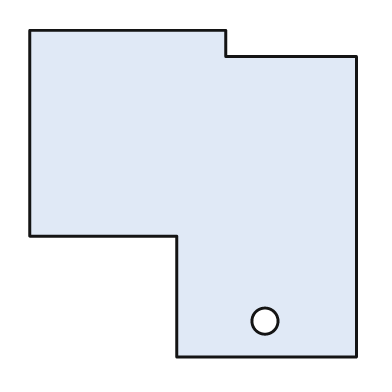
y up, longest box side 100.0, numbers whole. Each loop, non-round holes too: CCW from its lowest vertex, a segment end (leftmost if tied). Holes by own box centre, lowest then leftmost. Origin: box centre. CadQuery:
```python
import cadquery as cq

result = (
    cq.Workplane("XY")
    .moveTo(-5.0, -50.0)
    .lineTo(50.0, -50.0)
    .lineTo(50.0, 42.0)
    .lineTo(10.0, 42.0)
    .lineTo(10.0, 50.0)
    .lineTo(-50.0, 50.0)
    .lineTo(-50.0, -13.0)
    .lineTo(-5.0, -13.0)
    .close()
    .moveTo(22.0, -39.0)
    .circle(4.0)
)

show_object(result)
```